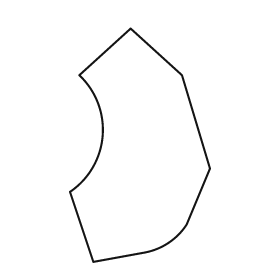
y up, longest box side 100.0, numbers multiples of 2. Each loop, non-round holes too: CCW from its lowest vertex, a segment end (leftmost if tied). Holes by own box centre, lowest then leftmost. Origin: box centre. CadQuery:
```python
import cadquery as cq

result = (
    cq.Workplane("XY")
    .moveTo(-20.0, -50.0)
    .lineTo(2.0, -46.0)
    .threePointArc((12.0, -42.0), (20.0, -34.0))
    .lineTo(30.0, -10.0)
    .lineTo(18.0, 30.0)
    .lineTo(-4.0, 50.0)
    .lineTo(-26.0, 30.0)
    .threePointArc((-16.0, 4.0), (-30.0, -20.0))
    .close()
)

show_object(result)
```